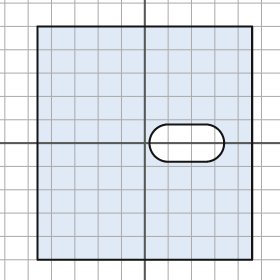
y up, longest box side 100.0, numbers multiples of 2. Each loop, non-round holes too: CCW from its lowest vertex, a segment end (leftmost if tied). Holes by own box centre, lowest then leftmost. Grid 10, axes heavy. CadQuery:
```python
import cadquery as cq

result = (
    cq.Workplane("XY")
    .moveTo(-46.0, -50.0)
    .lineTo(46.0, -50.0)
    .lineTo(46.0, 50.0)
    .lineTo(-46.0, 50.0)
    .close()
    .moveTo(10.0, -8.0)
    .lineTo(26.0, -8.0)
    .threePointArc((34.0, 0.0), (26.0, 8.0))
    .lineTo(10.0, 8.0)
    .threePointArc((2.0, 0.0), (10.0, -8.0))
    .close()
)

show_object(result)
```